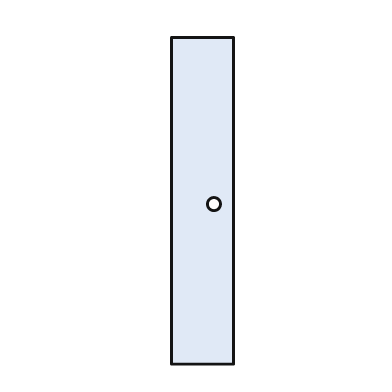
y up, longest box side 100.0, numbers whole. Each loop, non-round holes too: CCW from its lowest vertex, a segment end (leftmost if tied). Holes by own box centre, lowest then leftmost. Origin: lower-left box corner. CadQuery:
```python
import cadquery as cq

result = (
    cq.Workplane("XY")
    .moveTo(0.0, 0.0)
    .lineTo(19.0, 0.0)
    .lineTo(19.0, 100.0)
    .lineTo(0.0, 100.0)
    .close()
    .moveTo(13.0, 49.0)
    .circle(2.0)
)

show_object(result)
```